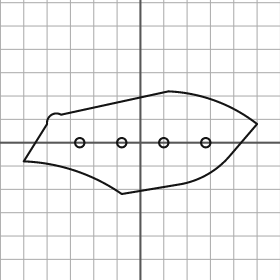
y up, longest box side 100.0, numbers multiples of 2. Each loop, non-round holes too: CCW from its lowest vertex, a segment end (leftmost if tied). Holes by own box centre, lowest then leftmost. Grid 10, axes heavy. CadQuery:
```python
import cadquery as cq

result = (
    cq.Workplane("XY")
    .moveTo(-8.0, -22.0)
    .lineTo(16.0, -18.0)
    .threePointArc((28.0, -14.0), (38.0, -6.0))
    .lineTo(50.0, 8.0)
    .threePointArc((32.0, 18.0), (12.0, 22.0))
    .lineTo(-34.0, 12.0)
    .threePointArc((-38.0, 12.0), (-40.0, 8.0))
    .lineTo(-50.0, -8.0)
    .threePointArc((-28.0, -12.0), (-8.0, -22.0))
    .close()
    .moveTo(-26.0, 0.0)
    .circle(2.0)
    .moveTo(-8.0, 0.0)
    .circle(2.0)
    .moveTo(10.0, 0.0)
    .circle(2.0)
    .moveTo(28.0, 0.0)
    .circle(2.0)
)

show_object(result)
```